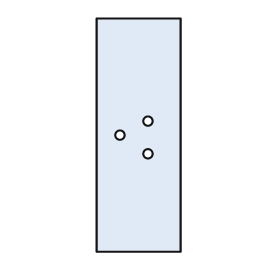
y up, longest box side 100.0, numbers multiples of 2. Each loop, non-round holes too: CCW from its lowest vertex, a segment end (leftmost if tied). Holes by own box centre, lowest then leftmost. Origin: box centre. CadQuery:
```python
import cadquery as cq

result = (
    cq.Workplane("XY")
    .moveTo(-18.0, -50.0)
    .lineTo(18.0, -50.0)
    .lineTo(18.0, 50.0)
    .lineTo(-18.0, 50.0)
    .close()
    .moveTo(4.0, -8.0)
    .circle(2.0)
    .moveTo(-8.0, 0.0)
    .circle(2.0)
    .moveTo(4.0, 6.0)
    .circle(2.0)
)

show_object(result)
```